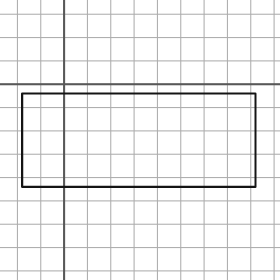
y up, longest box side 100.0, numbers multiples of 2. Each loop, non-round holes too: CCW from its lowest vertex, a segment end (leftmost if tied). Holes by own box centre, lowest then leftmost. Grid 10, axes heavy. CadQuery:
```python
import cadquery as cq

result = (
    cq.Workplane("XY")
    .moveTo(-18.0, -44.0)
    .lineTo(82.0, -44.0)
    .lineTo(82.0, -4.0)
    .lineTo(-18.0, -4.0)
    .close()
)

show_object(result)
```